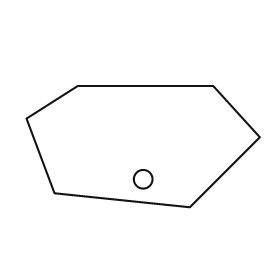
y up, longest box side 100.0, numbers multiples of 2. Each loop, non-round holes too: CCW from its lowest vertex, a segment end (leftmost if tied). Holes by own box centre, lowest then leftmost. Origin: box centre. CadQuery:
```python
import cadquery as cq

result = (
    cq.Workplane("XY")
    .moveTo(20.0, -26.0)
    .lineTo(50.0, 4.0)
    .lineTo(30.0, 26.0)
    .lineTo(-28.0, 26.0)
    .lineTo(-50.0, 12.0)
    .lineTo(-38.0, -20.0)
    .close()
    .moveTo(0.0, -14.0)
    .circle(4.0)
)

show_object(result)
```